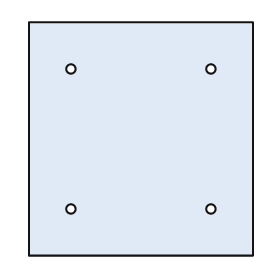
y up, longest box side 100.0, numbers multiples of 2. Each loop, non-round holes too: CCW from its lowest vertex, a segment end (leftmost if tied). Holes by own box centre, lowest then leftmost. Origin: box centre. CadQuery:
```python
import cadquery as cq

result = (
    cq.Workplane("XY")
    .moveTo(-48.0, -50.0)
    .lineTo(48.0, -50.0)
    .lineTo(48.0, 50.0)
    .lineTo(-48.0, 50.0)
    .close()
    .moveTo(-30.0, -30.0)
    .circle(2.0)
    .moveTo(30.0, -30.0)
    .circle(2.0)
    .moveTo(-30.0, 30.0)
    .circle(2.0)
    .moveTo(30.0, 30.0)
    .circle(2.0)
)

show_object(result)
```